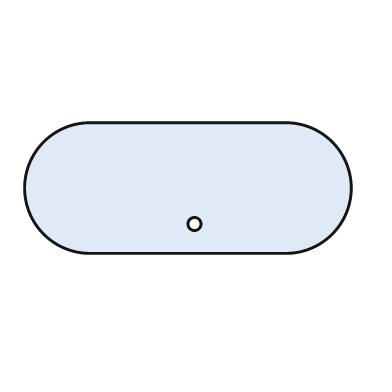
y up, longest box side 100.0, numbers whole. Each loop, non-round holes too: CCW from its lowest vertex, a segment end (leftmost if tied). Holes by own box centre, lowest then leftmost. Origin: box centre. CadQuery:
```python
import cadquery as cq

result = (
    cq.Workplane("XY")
    .moveTo(-30.0, -20.0)
    .lineTo(30.0, -20.0)
    .threePointArc((50.0, 0.0), (30.0, 20.0))
    .lineTo(-30.0, 20.0)
    .threePointArc((-50.0, 0.0), (-30.0, -20.0))
    .close()
    .moveTo(2.0, -11.0)
    .circle(2.0)
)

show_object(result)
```